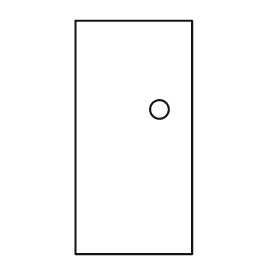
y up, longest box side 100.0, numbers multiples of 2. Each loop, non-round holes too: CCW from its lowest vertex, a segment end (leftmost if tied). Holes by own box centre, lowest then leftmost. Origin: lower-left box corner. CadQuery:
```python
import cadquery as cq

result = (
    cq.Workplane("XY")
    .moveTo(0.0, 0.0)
    .lineTo(50.0, 0.0)
    .lineTo(50.0, 100.0)
    .lineTo(0.0, 100.0)
    .close()
    .moveTo(36.0, 62.0)
    .circle(4.0)
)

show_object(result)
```